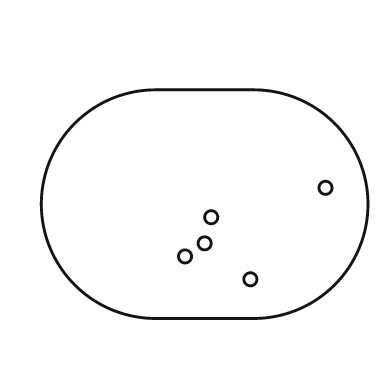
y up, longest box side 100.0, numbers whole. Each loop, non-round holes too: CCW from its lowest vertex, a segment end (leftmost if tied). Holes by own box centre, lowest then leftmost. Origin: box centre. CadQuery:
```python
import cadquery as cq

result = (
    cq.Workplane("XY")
    .moveTo(-15.0, -35.0)
    .lineTo(15.0, -35.0)
    .threePointArc((50.0, 0.0), (15.0, 35.0))
    .lineTo(-15.0, 35.0)
    .threePointArc((-50.0, 0.0), (-15.0, -35.0))
    .close()
    .moveTo(14.0, -23.0)
    .circle(2.0)
    .moveTo(-6.0, -16.0)
    .circle(2.0)
    .moveTo(0.0, -12.0)
    .circle(2.0)
    .moveTo(2.0, -4.0)
    .circle(2.0)
    .moveTo(37.0, 5.0)
    .circle(2.0)
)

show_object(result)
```